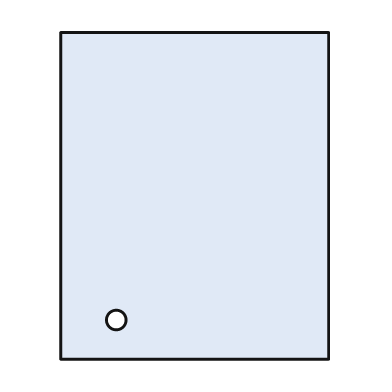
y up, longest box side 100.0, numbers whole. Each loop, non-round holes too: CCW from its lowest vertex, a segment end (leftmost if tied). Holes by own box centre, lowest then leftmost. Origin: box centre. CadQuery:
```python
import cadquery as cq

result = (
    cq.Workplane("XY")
    .moveTo(-41.0, -50.0)
    .lineTo(41.0, -50.0)
    .lineTo(41.0, 50.0)
    .lineTo(-41.0, 50.0)
    .close()
    .moveTo(-24.0, -38.0)
    .circle(3.0)
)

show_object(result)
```